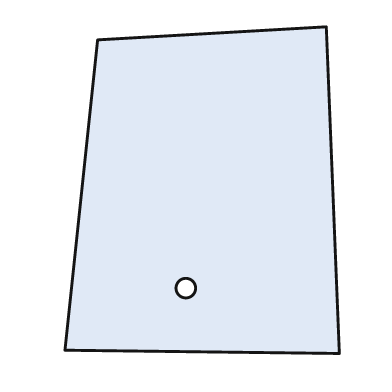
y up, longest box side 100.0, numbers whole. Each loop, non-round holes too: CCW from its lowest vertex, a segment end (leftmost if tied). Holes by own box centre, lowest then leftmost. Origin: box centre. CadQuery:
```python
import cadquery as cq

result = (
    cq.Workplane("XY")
    .moveTo(42.0, -50.0)
    .lineTo(38.0, 50.0)
    .lineTo(-32.0, 46.0)
    .lineTo(-42.0, -49.0)
    .close()
    .moveTo(-5.0, -30.0)
    .circle(3.0)
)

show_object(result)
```